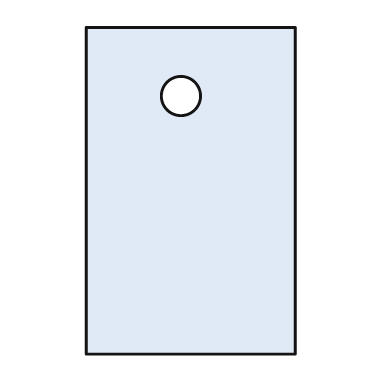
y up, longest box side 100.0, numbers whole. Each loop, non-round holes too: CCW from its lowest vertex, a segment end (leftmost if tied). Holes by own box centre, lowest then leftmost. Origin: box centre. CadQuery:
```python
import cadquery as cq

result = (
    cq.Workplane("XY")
    .moveTo(-32.0, -50.0)
    .lineTo(32.0, -50.0)
    .lineTo(32.0, 50.0)
    .lineTo(-32.0, 50.0)
    .close()
    .moveTo(-3.0, 29.0)
    .circle(6.0)
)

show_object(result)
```